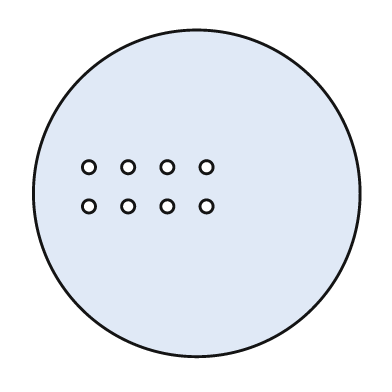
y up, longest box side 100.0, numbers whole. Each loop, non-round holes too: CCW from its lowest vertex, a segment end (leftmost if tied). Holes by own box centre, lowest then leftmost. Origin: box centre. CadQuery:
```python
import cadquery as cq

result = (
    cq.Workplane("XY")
    .moveTo(0.0, 0.0)
    .circle(50.0)
    .moveTo(-33.0, -4.0)
    .circle(2.0)
    .moveTo(-21.0, -4.0)
    .circle(2.0)
    .moveTo(-9.0, -4.0)
    .circle(2.0)
    .moveTo(3.0, -4.0)
    .circle(2.0)
    .moveTo(-33.0, 8.0)
    .circle(2.0)
    .moveTo(-21.0, 8.0)
    .circle(2.0)
    .moveTo(-9.0, 8.0)
    .circle(2.0)
    .moveTo(3.0, 8.0)
    .circle(2.0)
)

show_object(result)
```